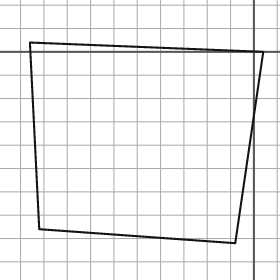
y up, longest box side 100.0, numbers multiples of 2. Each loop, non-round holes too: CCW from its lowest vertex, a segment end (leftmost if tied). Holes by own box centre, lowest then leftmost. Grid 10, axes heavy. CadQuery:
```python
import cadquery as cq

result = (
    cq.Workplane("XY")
    .moveTo(-8.0, -82.0)
    .lineTo(4.0, 0.0)
    .lineTo(-96.0, 4.0)
    .lineTo(-92.0, -76.0)
    .close()
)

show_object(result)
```